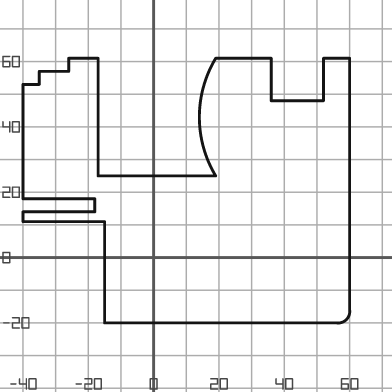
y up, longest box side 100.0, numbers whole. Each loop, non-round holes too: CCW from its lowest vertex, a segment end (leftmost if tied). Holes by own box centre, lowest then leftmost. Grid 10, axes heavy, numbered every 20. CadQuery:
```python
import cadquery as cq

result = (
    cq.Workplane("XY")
    .moveTo(-15.0, -20.0)
    .lineTo(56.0, -20.0)
    .threePointArc((59.0, -19.0), (60.0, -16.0))
    .lineTo(60.0, 61.0)
    .lineTo(52.0, 61.0)
    .lineTo(52.0, 48.0)
    .lineTo(36.0, 48.0)
    .lineTo(36.0, 61.0)
    .lineTo(19.0, 61.0)
    .threePointArc((14.0, 43.0), (19.0, 25.0))
    .lineTo(-17.0, 25.0)
    .lineTo(-17.0, 61.0)
    .lineTo(-26.0, 61.0)
    .lineTo(-26.0, 57.0)
    .lineTo(-35.0, 57.0)
    .lineTo(-35.0, 53.0)
    .lineTo(-40.0, 53.0)
    .lineTo(-40.0, 18.0)
    .lineTo(-18.0, 18.0)
    .lineTo(-18.0, 14.0)
    .lineTo(-40.0, 14.0)
    .lineTo(-40.0, 11.0)
    .lineTo(-15.0, 11.0)
    .close()
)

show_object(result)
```